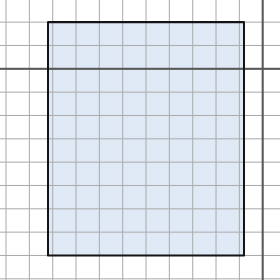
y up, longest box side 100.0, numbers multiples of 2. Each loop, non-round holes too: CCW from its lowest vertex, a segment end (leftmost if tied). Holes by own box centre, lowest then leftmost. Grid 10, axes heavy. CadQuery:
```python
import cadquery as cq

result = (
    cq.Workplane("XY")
    .moveTo(-92.0, -80.0)
    .lineTo(-8.0, -80.0)
    .lineTo(-8.0, 20.0)
    .lineTo(-92.0, 20.0)
    .close()
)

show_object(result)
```